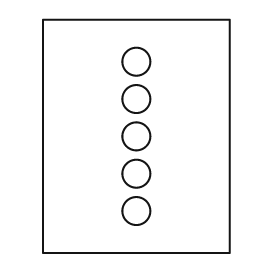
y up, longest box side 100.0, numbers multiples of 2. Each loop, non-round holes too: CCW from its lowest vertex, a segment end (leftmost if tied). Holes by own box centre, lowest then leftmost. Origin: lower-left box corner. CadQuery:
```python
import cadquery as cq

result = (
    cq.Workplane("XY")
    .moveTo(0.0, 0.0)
    .lineTo(80.0, 0.0)
    .lineTo(80.0, 100.0)
    .lineTo(0.0, 100.0)
    .close()
    .moveTo(40.0, 18.0)
    .circle(6.0)
    .moveTo(40.0, 34.0)
    .circle(6.0)
    .moveTo(40.0, 50.0)
    .circle(6.0)
    .moveTo(40.0, 66.0)
    .circle(6.0)
    .moveTo(40.0, 82.0)
    .circle(6.0)
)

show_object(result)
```